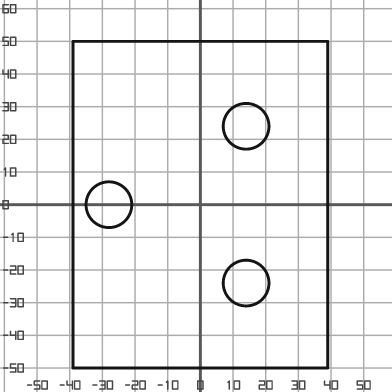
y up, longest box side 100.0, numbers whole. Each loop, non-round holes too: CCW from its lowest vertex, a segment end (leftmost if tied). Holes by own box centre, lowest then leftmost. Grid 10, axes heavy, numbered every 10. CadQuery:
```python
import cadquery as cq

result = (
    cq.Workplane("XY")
    .moveTo(-39.0, -50.0)
    .lineTo(39.0, -50.0)
    .lineTo(39.0, 50.0)
    .lineTo(-39.0, 50.0)
    .close()
    .moveTo(14.0, -24.0)
    .circle(7.0)
    .moveTo(-28.0, 0.0)
    .circle(7.0)
    .moveTo(14.0, 24.0)
    .circle(7.0)
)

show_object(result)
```